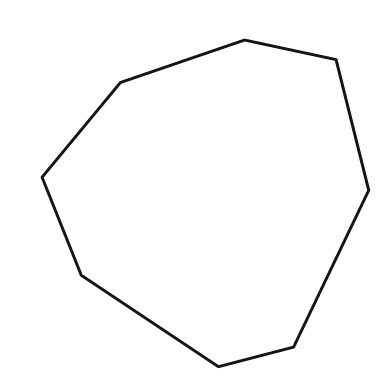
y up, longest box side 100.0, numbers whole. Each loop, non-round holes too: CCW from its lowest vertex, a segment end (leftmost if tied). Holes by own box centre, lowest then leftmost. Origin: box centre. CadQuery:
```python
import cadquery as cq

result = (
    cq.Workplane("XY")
    .moveTo(4.0, -50.0)
    .lineTo(27.0, -44.0)
    .lineTo(50.0, 4.0)
    .lineTo(40.0, 44.0)
    .lineTo(12.0, 50.0)
    .lineTo(-26.0, 37.0)
    .lineTo(-50.0, 8.0)
    .lineTo(-38.0, -22.0)
    .close()
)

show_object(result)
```